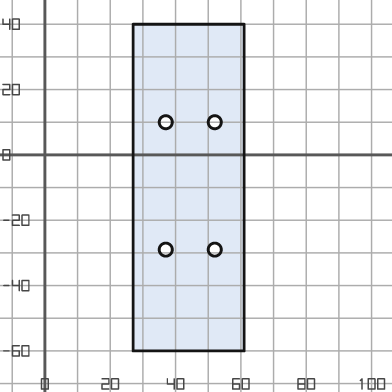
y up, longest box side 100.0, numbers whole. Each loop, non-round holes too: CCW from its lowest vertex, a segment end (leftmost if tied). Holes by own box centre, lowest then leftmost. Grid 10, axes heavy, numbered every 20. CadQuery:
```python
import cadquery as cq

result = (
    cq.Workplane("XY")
    .moveTo(27.0, -60.0)
    .lineTo(61.0, -60.0)
    .lineTo(61.0, 40.0)
    .lineTo(27.0, 40.0)
    .close()
    .moveTo(37.0, -29.0)
    .circle(2.0)
    .moveTo(52.0, -29.0)
    .circle(2.0)
    .moveTo(37.0, 10.0)
    .circle(2.0)
    .moveTo(52.0, 10.0)
    .circle(2.0)
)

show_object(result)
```